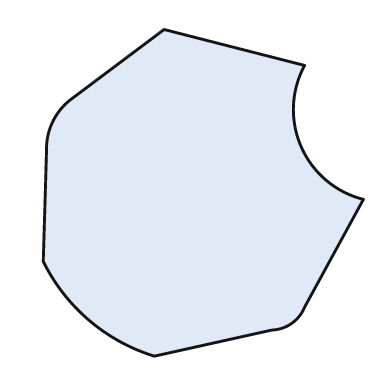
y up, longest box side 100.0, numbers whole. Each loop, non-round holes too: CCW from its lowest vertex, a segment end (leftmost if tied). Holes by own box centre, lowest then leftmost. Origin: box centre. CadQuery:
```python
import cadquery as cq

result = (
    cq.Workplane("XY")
    .moveTo(-15.0, -50.0)
    .lineTo(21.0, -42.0)
    .threePointArc((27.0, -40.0), (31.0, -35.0))
    .lineTo(49.0, -2.0)
    .threePointArc((30.0, 14.0), (31.0, 39.0))
    .lineTo(-12.0, 50.0)
    .lineTo(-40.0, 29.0)
    .threePointArc((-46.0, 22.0), (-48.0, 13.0))
    .lineTo(-49.0, -21.0)
    .threePointArc((-35.0, -39.0), (-15.0, -50.0))
    .close()
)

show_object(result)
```